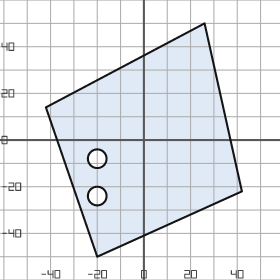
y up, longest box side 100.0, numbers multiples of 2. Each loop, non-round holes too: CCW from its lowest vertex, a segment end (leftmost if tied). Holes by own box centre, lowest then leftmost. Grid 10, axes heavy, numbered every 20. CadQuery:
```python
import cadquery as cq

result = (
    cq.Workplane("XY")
    .moveTo(-20.0, -50.0)
    .lineTo(42.0, -22.0)
    .lineTo(26.0, 50.0)
    .lineTo(-42.0, 14.0)
    .close()
    .moveTo(-20.0, -24.0)
    .circle(4.0)
    .moveTo(-20.0, -8.0)
    .circle(4.0)
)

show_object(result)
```